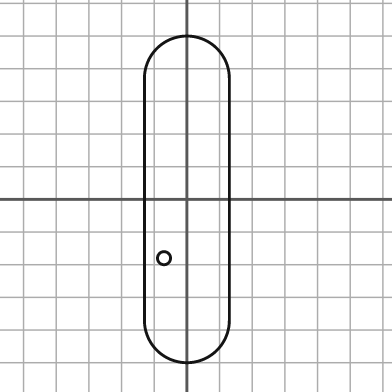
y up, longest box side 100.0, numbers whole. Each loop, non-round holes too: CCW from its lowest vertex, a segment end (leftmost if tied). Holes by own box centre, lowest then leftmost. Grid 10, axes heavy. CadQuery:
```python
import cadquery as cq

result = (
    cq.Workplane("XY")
    .moveTo(-13.0, -37.0)
    .threePointArc((0.0, -50.0), (13.0, -37.0))
    .lineTo(13.0, 37.0)
    .threePointArc((0.0, 50.0), (-13.0, 37.0))
    .close()
    .moveTo(-7.0, -18.0)
    .circle(2.0)
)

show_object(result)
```